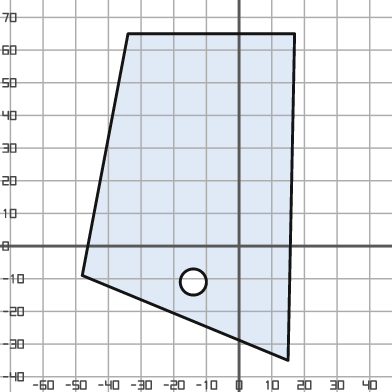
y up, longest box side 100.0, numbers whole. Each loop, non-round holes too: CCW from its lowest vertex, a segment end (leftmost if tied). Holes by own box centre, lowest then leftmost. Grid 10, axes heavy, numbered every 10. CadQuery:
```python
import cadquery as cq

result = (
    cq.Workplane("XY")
    .moveTo(15.0, -35.0)
    .lineTo(17.0, 65.0)
    .lineTo(-34.0, 65.0)
    .lineTo(-48.0, -9.0)
    .close()
    .moveTo(-14.0, -11.0)
    .circle(4.0)
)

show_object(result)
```